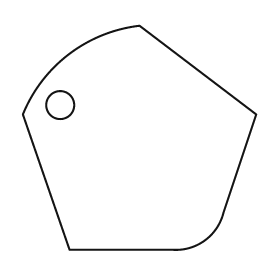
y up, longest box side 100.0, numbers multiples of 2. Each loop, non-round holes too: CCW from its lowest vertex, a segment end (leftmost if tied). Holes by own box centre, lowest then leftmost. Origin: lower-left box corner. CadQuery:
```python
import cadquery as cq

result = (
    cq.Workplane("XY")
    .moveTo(20.0, 0.0)
    .lineTo(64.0, 0.0)
    .threePointArc((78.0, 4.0), (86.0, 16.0))
    .lineTo(100.0, 58.0)
    .lineTo(50.0, 96.0)
    .threePointArc((20.0, 84.0), (0.0, 58.0))
    .close()
    .moveTo(16.0, 62.0)
    .circle(6.0)
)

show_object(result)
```